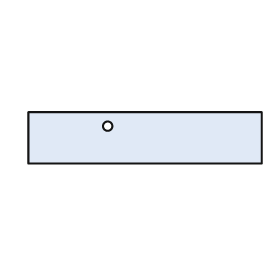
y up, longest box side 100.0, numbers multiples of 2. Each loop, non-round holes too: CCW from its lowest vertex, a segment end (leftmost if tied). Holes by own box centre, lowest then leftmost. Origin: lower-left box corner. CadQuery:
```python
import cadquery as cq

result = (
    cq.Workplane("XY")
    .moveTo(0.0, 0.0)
    .lineTo(100.0, 0.0)
    .lineTo(100.0, 22.0)
    .lineTo(0.0, 22.0)
    .close()
    .moveTo(34.0, 16.0)
    .circle(2.0)
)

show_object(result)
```